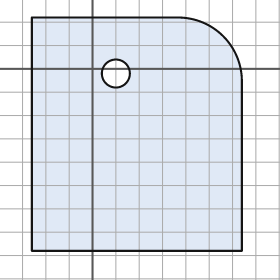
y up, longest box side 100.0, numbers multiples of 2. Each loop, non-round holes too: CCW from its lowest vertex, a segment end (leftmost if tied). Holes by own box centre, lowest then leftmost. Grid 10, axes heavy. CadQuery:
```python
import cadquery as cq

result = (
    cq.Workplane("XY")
    .moveTo(-26.0, -78.0)
    .lineTo(64.0, -78.0)
    .lineTo(64.0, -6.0)
    .threePointArc((56.0, 14.0), (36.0, 22.0))
    .lineTo(-26.0, 22.0)
    .close()
    .moveTo(10.0, -2.0)
    .circle(6.0)
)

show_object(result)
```